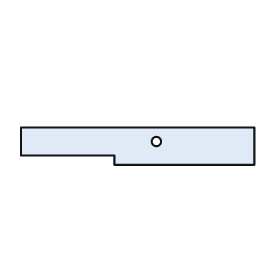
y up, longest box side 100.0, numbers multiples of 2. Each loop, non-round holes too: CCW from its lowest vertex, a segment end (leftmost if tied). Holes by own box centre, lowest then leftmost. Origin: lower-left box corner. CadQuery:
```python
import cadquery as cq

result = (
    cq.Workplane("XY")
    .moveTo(40.0, 0.0)
    .lineTo(100.0, 0.0)
    .lineTo(100.0, 16.0)
    .lineTo(0.0, 16.0)
    .lineTo(0.0, 4.0)
    .lineTo(40.0, 4.0)
    .close()
    .moveTo(58.0, 10.0)
    .circle(2.0)
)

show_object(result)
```